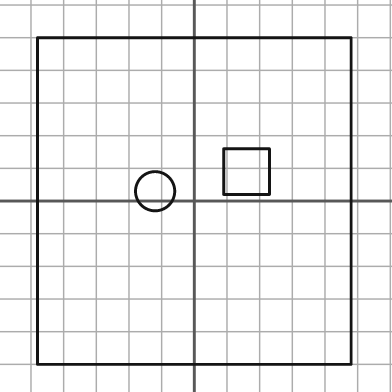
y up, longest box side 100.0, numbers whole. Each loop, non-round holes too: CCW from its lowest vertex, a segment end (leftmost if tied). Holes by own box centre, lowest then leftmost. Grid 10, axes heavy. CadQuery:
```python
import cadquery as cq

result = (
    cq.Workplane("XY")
    .moveTo(-48.0, -50.0)
    .lineTo(48.0, -50.0)
    .lineTo(48.0, 50.0)
    .lineTo(-48.0, 50.0)
    .close()
    .moveTo(-12.0, 3.0)
    .circle(6.0)
    .moveTo(9.0, 2.0)
    .lineTo(23.0, 2.0)
    .lineTo(23.0, 16.0)
    .lineTo(9.0, 16.0)
    .close()
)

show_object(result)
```